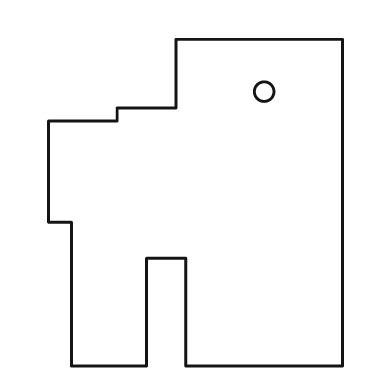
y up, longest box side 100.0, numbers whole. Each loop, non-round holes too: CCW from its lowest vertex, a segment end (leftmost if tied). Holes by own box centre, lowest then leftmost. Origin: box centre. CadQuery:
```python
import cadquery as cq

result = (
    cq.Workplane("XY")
    .moveTo(-38.0, -50.0)
    .lineTo(-15.0, -50.0)
    .lineTo(-15.0, -17.0)
    .lineTo(-3.0, -17.0)
    .lineTo(-3.0, -50.0)
    .lineTo(45.0, -50.0)
    .lineTo(45.0, 50.0)
    .lineTo(-6.0, 50.0)
    .lineTo(-6.0, 29.0)
    .lineTo(-24.0, 29.0)
    .lineTo(-24.0, 25.0)
    .lineTo(-45.0, 25.0)
    .lineTo(-45.0, -6.0)
    .lineTo(-38.0, -6.0)
    .close()
    .moveTo(21.0, 34.0)
    .circle(3.0)
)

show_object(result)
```